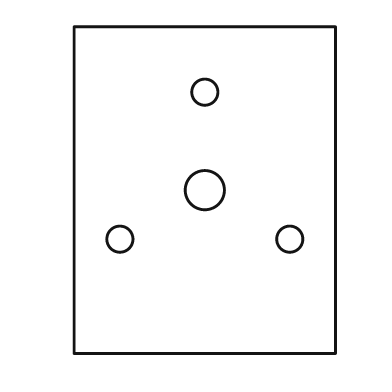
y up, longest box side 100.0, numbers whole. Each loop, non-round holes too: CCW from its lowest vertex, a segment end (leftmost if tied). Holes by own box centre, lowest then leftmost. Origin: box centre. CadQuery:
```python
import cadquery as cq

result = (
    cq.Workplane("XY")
    .moveTo(-40.0, -50.0)
    .lineTo(40.0, -50.0)
    .lineTo(40.0, 50.0)
    .lineTo(-40.0, 50.0)
    .close()
    .moveTo(-26.0, -15.0)
    .circle(4.0)
    .moveTo(26.0, -15.0)
    .circle(4.0)
    .moveTo(0.0, 0.0)
    .circle(6.0)
    .moveTo(0.0, 30.0)
    .circle(4.0)
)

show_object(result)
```